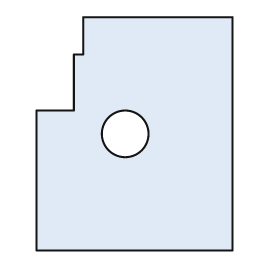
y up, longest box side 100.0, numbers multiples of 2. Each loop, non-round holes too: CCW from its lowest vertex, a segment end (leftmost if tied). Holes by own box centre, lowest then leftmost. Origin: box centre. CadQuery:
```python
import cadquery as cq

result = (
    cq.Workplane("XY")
    .moveTo(-42.0, -50.0)
    .lineTo(42.0, -50.0)
    .lineTo(42.0, 50.0)
    .lineTo(-22.0, 50.0)
    .lineTo(-22.0, 34.0)
    .lineTo(-26.0, 34.0)
    .lineTo(-26.0, 10.0)
    .lineTo(-42.0, 10.0)
    .close()
    .moveTo(-4.0, 0.0)
    .circle(10.0)
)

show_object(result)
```